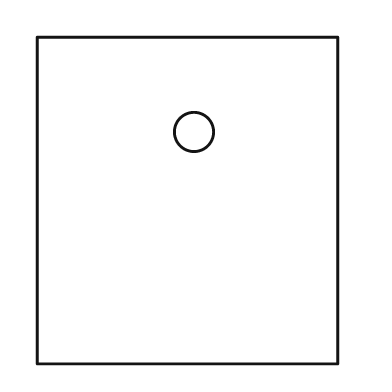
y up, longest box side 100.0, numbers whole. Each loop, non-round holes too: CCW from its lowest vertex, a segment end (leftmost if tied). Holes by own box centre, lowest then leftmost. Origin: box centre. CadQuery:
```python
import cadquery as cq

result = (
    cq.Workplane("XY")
    .moveTo(-46.0, -50.0)
    .lineTo(46.0, -50.0)
    .lineTo(46.0, 50.0)
    .lineTo(-46.0, 50.0)
    .close()
    .moveTo(2.0, 21.0)
    .circle(6.0)
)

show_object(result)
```